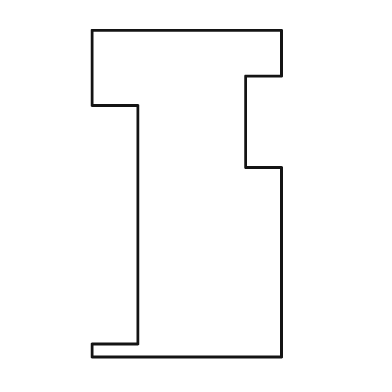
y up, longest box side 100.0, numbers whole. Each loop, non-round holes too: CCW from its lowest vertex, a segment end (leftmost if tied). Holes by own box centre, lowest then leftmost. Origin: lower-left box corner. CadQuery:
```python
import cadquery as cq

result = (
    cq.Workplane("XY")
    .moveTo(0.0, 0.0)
    .lineTo(58.0, 0.0)
    .lineTo(58.0, 58.0)
    .lineTo(47.0, 58.0)
    .lineTo(47.0, 86.0)
    .lineTo(58.0, 86.0)
    .lineTo(58.0, 100.0)
    .lineTo(0.0, 100.0)
    .lineTo(0.0, 77.0)
    .lineTo(14.0, 77.0)
    .lineTo(14.0, 4.0)
    .lineTo(0.0, 4.0)
    .close()
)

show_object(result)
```